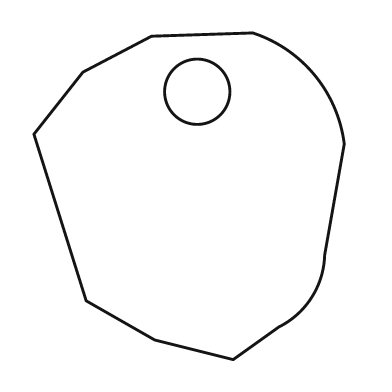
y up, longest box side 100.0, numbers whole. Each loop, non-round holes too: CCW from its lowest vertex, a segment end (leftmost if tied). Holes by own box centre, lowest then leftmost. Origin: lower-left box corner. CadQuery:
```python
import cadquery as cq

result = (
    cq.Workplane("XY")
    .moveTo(61.0, 0.0)
    .lineTo(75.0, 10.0)
    .threePointArc((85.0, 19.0), (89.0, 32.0))
    .lineTo(95.0, 66.0)
    .threePointArc((86.0, 87.0), (67.0, 100.0))
    .lineTo(36.0, 99.0)
    .lineTo(15.0, 88.0)
    .lineTo(0.0, 69.0)
    .lineTo(16.0, 18.0)
    .lineTo(37.0, 6.0)
    .close()
    .moveTo(50.0, 82.0)
    .circle(10.0)
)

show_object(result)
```